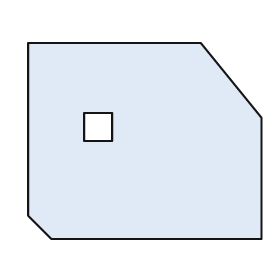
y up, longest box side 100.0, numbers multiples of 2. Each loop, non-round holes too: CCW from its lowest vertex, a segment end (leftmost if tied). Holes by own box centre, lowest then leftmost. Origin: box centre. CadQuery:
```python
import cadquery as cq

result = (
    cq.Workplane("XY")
    .moveTo(-40.0, -42.0)
    .lineTo(50.0, -42.0)
    .lineTo(50.0, 10.0)
    .lineTo(24.0, 42.0)
    .lineTo(-50.0, 42.0)
    .lineTo(-50.0, -32.0)
    .close()
    .moveTo(-26.0, 0.0)
    .lineTo(-14.0, 0.0)
    .lineTo(-14.0, 12.0)
    .lineTo(-26.0, 12.0)
    .close()
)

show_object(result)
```